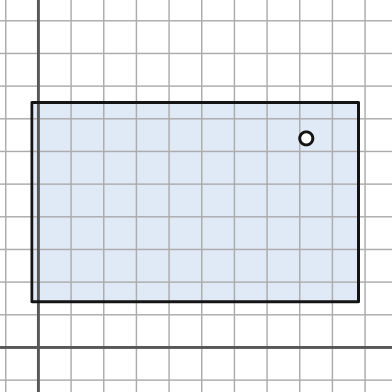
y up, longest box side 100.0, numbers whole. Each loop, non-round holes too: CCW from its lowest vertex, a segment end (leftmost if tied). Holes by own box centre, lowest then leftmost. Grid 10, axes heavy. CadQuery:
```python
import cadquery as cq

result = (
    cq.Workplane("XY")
    .moveTo(-2.0, 14.0)
    .lineTo(98.0, 14.0)
    .lineTo(98.0, 75.0)
    .lineTo(-2.0, 75.0)
    .close()
    .moveTo(82.0, 64.0)
    .circle(2.0)
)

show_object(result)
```